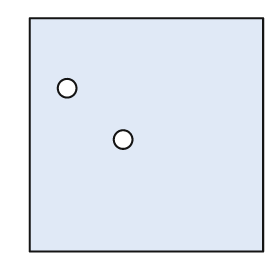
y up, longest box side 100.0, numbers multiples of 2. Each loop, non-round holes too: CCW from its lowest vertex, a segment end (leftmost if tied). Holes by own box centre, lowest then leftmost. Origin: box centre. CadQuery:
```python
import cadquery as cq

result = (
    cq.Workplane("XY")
    .moveTo(-50.0, -50.0)
    .lineTo(50.0, -50.0)
    .lineTo(50.0, 50.0)
    .lineTo(-50.0, 50.0)
    .close()
    .moveTo(-10.0, -2.0)
    .circle(4.0)
    .moveTo(-34.0, 20.0)
    .circle(4.0)
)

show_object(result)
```